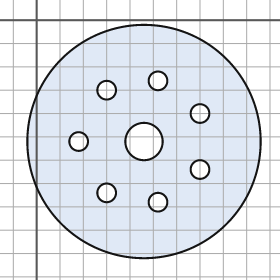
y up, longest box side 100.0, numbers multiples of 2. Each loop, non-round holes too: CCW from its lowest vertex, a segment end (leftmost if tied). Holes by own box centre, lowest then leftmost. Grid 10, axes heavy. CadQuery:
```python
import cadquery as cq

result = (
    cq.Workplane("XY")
    .moveTo(46.0, -52.0)
    .circle(50.0)
    .moveTo(52.0, -78.0)
    .circle(4.0)
    .moveTo(30.0, -74.0)
    .circle(4.0)
    .moveTo(70.0, -64.0)
    .circle(4.0)
    .moveTo(18.0, -52.0)
    .circle(4.0)
    .moveTo(46.0, -52.0)
    .circle(8.0)
    .moveTo(70.0, -40.0)
    .circle(4.0)
    .moveTo(30.0, -30.0)
    .circle(4.0)
    .moveTo(52.0, -26.0)
    .circle(4.0)
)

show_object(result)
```